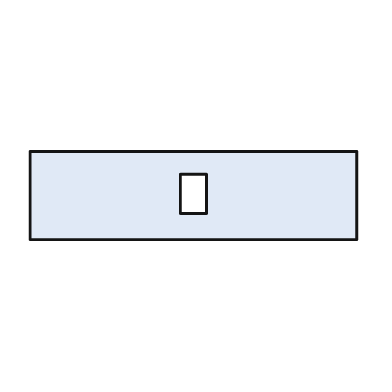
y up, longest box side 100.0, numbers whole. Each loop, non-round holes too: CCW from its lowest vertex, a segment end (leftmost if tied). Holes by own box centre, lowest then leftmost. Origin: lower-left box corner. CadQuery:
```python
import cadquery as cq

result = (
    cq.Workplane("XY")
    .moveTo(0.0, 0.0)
    .lineTo(100.0, 0.0)
    .lineTo(100.0, 27.0)
    .lineTo(0.0, 27.0)
    .close()
    .moveTo(46.0, 8.0)
    .lineTo(54.0, 8.0)
    .lineTo(54.0, 20.0)
    .lineTo(46.0, 20.0)
    .close()
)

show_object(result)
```